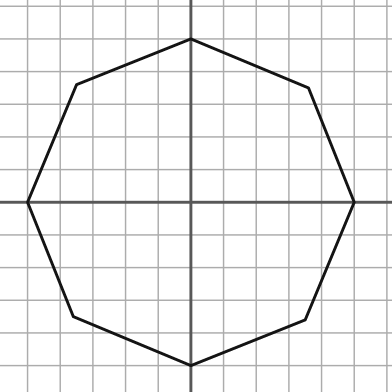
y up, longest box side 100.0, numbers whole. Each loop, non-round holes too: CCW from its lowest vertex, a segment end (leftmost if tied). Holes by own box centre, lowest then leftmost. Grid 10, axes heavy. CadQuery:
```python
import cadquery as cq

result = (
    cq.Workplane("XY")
    .moveTo(0.0, -50.0)
    .lineTo(35.0, -36.0)
    .lineTo(50.0, 0.0)
    .lineTo(36.0, 35.0)
    .lineTo(0.0, 50.0)
    .lineTo(-35.0, 36.0)
    .lineTo(-50.0, 0.0)
    .lineTo(-36.0, -35.0)
    .close()
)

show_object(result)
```